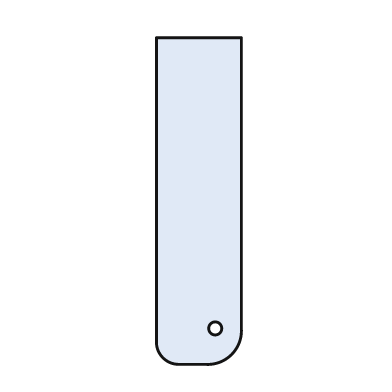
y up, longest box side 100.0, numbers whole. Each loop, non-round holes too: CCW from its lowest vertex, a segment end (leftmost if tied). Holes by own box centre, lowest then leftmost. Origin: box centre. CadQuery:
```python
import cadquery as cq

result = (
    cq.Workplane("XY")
    .moveTo(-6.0, -50.0)
    .lineTo(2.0, -50.0)
    .threePointArc((10.0, -47.0), (13.0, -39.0))
    .lineTo(13.0, 50.0)
    .lineTo(-13.0, 50.0)
    .lineTo(-13.0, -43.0)
    .threePointArc((-11.0, -48.0), (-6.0, -50.0))
    .close()
    .moveTo(5.0, -39.0)
    .circle(2.0)
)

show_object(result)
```